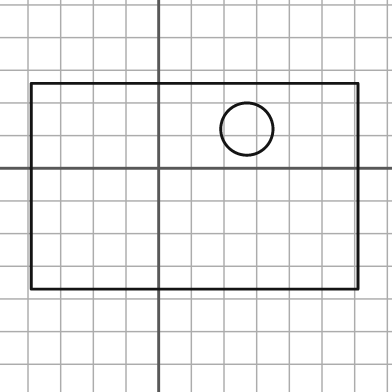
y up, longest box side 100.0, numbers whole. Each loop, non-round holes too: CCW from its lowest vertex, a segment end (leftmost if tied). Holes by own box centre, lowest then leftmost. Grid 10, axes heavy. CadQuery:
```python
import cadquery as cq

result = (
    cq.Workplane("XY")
    .moveTo(-39.0, -37.0)
    .lineTo(61.0, -37.0)
    .lineTo(61.0, 26.0)
    .lineTo(-39.0, 26.0)
    .close()
    .moveTo(27.0, 12.0)
    .circle(8.0)
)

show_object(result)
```